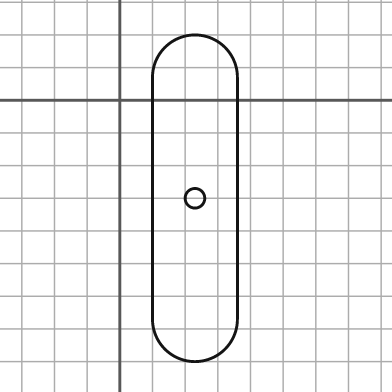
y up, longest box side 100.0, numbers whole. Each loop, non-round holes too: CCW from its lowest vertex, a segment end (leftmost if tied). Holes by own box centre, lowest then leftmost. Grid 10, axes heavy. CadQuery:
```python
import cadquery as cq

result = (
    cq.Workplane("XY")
    .moveTo(10.0, -67.0)
    .threePointArc((23.0, -80.0), (36.0, -67.0))
    .lineTo(36.0, 7.0)
    .threePointArc((23.0, 20.0), (10.0, 7.0))
    .close()
    .moveTo(23.0, -30.0)
    .circle(3.0)
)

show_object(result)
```